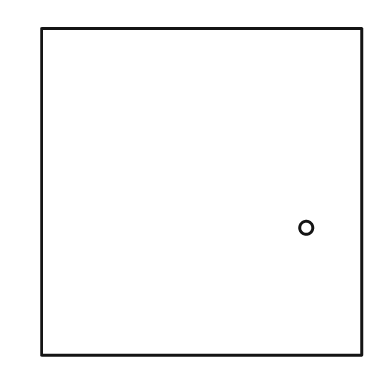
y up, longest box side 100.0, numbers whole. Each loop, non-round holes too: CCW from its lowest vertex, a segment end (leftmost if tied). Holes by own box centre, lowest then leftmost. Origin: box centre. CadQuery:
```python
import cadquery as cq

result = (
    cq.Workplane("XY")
    .moveTo(-49.0, -50.0)
    .lineTo(49.0, -50.0)
    .lineTo(49.0, 50.0)
    .lineTo(-49.0, 50.0)
    .close()
    .moveTo(32.0, -11.0)
    .circle(2.0)
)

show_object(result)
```